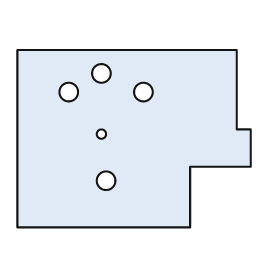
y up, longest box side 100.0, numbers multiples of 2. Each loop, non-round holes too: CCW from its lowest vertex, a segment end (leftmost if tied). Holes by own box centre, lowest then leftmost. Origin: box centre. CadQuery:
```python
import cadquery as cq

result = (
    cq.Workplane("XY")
    .moveTo(-50.0, -38.0)
    .lineTo(24.0, -38.0)
    .lineTo(24.0, -12.0)
    .lineTo(50.0, -12.0)
    .lineTo(50.0, 4.0)
    .lineTo(44.0, 4.0)
    .lineTo(44.0, 38.0)
    .lineTo(-50.0, 38.0)
    .close()
    .moveTo(-12.0, -18.0)
    .circle(4.0)
    .moveTo(-14.0, 2.0)
    .circle(2.0)
    .moveTo(-28.0, 20.0)
    .circle(4.0)
    .moveTo(4.0, 20.0)
    .circle(4.0)
    .moveTo(-14.0, 28.0)
    .circle(4.0)
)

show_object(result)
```